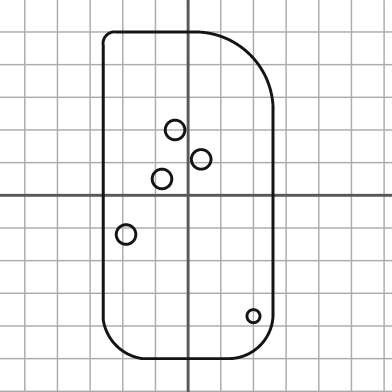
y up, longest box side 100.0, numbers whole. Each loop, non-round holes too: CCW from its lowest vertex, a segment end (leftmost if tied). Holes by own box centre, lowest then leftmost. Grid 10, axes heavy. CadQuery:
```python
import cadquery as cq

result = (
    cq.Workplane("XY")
    .moveTo(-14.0, -50.0)
    .lineTo(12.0, -50.0)
    .threePointArc((22.0, -46.0), (26.0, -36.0))
    .lineTo(26.0, 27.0)
    .threePointArc((19.0, 43.0), (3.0, 50.0))
    .lineTo(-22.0, 50.0)
    .threePointArc((-25.0, 49.0), (-26.0, 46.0))
    .lineTo(-26.0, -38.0)
    .threePointArc((-22.0, -46.0), (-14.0, -50.0))
    .close()
    .moveTo(20.0, -37.0)
    .circle(2.0)
    .moveTo(-19.0, -12.0)
    .circle(3.0)
    .moveTo(-8.0, 5.0)
    .circle(3.0)
    .moveTo(4.0, 11.0)
    .circle(3.0)
    .moveTo(-4.0, 20.0)
    .circle(3.0)
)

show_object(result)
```